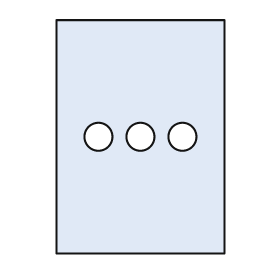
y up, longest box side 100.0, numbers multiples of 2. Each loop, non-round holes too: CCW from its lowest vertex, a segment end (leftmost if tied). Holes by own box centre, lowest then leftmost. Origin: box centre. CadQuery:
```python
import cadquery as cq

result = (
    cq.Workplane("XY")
    .moveTo(-36.0, -50.0)
    .lineTo(36.0, -50.0)
    .lineTo(36.0, 50.0)
    .lineTo(-36.0, 50.0)
    .close()
    .moveTo(-18.0, 0.0)
    .circle(6.0)
    .moveTo(0.0, 0.0)
    .circle(6.0)
    .moveTo(18.0, 0.0)
    .circle(6.0)
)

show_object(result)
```